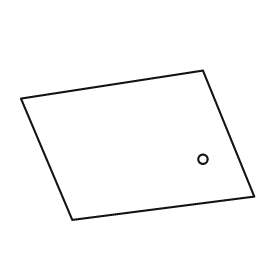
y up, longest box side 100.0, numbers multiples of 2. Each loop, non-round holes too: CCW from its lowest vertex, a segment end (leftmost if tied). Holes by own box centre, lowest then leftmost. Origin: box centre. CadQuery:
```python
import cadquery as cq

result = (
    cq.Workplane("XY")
    .moveTo(-28.0, -32.0)
    .lineTo(50.0, -22.0)
    .lineTo(28.0, 32.0)
    .lineTo(-50.0, 20.0)
    .close()
    .moveTo(28.0, -6.0)
    .circle(2.0)
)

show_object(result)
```